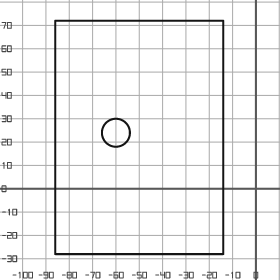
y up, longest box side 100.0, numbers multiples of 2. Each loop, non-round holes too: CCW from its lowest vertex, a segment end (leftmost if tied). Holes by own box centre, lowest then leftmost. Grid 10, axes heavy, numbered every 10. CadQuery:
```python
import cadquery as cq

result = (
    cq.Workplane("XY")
    .moveTo(-86.0, -28.0)
    .lineTo(-14.0, -28.0)
    .lineTo(-14.0, 72.0)
    .lineTo(-86.0, 72.0)
    .close()
    .moveTo(-60.0, 24.0)
    .circle(6.0)
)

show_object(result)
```